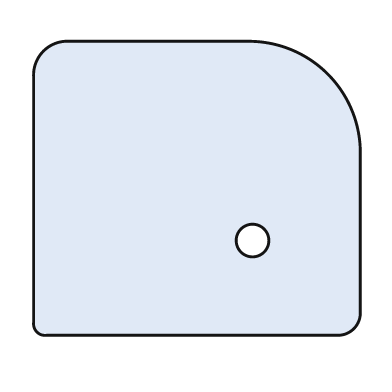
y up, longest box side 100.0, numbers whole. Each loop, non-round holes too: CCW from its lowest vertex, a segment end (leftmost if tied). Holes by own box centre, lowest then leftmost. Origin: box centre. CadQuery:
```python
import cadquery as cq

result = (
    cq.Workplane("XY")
    .moveTo(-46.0, -45.0)
    .lineTo(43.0, -45.0)
    .threePointArc((48.0, -43.0), (50.0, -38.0))
    .lineTo(50.0, 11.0)
    .threePointArc((40.0, 35.0), (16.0, 45.0))
    .lineTo(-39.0, 45.0)
    .threePointArc((-47.0, 42.0), (-50.0, 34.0))
    .lineTo(-50.0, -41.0)
    .threePointArc((-49.0, -44.0), (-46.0, -45.0))
    .close()
    .moveTo(17.0, -16.0)
    .circle(5.0)
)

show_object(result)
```